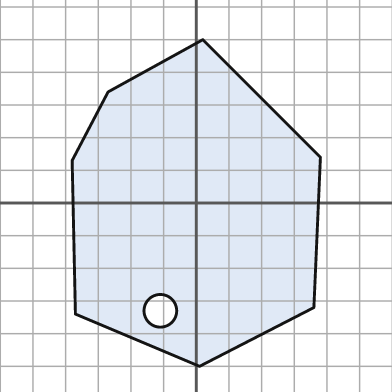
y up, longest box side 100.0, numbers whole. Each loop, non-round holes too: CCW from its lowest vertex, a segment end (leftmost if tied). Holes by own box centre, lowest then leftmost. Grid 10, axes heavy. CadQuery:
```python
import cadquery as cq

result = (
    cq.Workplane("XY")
    .moveTo(1.0, -50.0)
    .lineTo(36.0, -32.0)
    .lineTo(38.0, 14.0)
    .lineTo(2.0, 50.0)
    .lineTo(-27.0, 34.0)
    .lineTo(-38.0, 13.0)
    .lineTo(-37.0, -34.0)
    .close()
    .moveTo(-11.0, -33.0)
    .circle(5.0)
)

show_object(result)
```